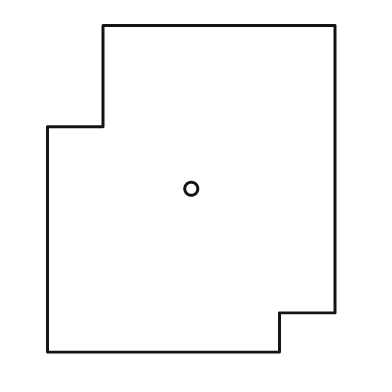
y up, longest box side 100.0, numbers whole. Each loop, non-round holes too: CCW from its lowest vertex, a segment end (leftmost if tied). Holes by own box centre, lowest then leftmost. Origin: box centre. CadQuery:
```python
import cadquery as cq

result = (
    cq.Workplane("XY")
    .moveTo(-44.0, -50.0)
    .lineTo(27.0, -50.0)
    .lineTo(27.0, -38.0)
    .lineTo(44.0, -38.0)
    .lineTo(44.0, 50.0)
    .lineTo(-27.0, 50.0)
    .lineTo(-27.0, 19.0)
    .lineTo(-44.0, 19.0)
    .close()
    .moveTo(0.0, 0.0)
    .circle(2.0)
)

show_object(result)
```